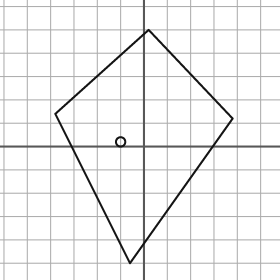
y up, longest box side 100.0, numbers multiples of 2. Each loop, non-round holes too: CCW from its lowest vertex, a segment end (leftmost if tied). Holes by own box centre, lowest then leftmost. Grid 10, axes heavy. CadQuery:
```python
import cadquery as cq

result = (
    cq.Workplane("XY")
    .moveTo(-6.0, -50.0)
    .lineTo(38.0, 12.0)
    .lineTo(2.0, 50.0)
    .lineTo(-38.0, 14.0)
    .close()
    .moveTo(-10.0, 2.0)
    .circle(2.0)
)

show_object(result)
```